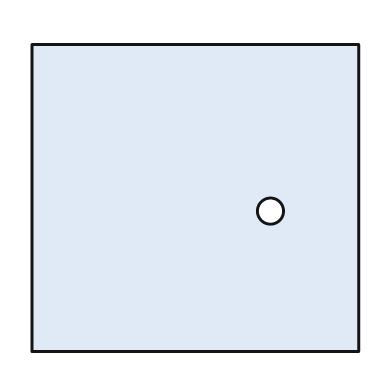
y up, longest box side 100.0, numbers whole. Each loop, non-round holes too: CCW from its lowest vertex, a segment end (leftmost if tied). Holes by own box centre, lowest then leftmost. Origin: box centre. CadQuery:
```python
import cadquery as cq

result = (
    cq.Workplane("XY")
    .moveTo(-50.0, -47.0)
    .lineTo(50.0, -47.0)
    .lineTo(50.0, 47.0)
    .lineTo(-50.0, 47.0)
    .close()
    .moveTo(23.0, -4.0)
    .circle(4.0)
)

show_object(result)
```